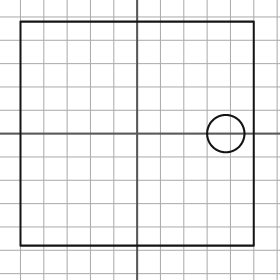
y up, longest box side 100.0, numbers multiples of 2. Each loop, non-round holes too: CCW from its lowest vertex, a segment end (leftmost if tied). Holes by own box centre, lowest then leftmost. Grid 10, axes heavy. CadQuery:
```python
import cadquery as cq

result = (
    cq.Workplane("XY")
    .moveTo(-50.0, -48.0)
    .lineTo(50.0, -48.0)
    .lineTo(50.0, 48.0)
    .lineTo(-50.0, 48.0)
    .close()
    .moveTo(38.0, 0.0)
    .circle(8.0)
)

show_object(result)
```